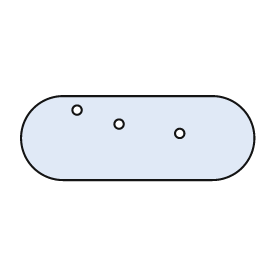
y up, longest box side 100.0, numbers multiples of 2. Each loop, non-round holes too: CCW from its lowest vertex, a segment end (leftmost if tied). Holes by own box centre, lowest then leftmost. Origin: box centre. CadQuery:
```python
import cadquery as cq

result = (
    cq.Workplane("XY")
    .moveTo(-32.0, -18.0)
    .lineTo(32.0, -18.0)
    .threePointArc((50.0, 0.0), (32.0, 18.0))
    .lineTo(-32.0, 18.0)
    .threePointArc((-50.0, 0.0), (-32.0, -18.0))
    .close()
    .moveTo(18.0, 2.0)
    .circle(2.0)
    .moveTo(-8.0, 6.0)
    .circle(2.0)
    .moveTo(-26.0, 12.0)
    .circle(2.0)
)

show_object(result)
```